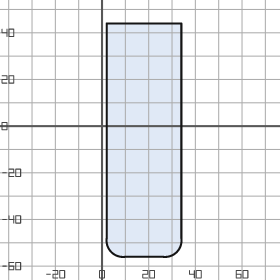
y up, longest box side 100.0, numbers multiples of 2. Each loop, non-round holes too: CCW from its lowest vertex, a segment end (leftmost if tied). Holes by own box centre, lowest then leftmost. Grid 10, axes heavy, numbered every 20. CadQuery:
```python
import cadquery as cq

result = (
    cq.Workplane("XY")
    .moveTo(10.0, -56.0)
    .lineTo(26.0, -56.0)
    .threePointArc((32.0, -54.0), (34.0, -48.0))
    .lineTo(34.0, 44.0)
    .lineTo(2.0, 44.0)
    .lineTo(2.0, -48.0)
    .threePointArc((4.0, -54.0), (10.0, -56.0))
    .close()
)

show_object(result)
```